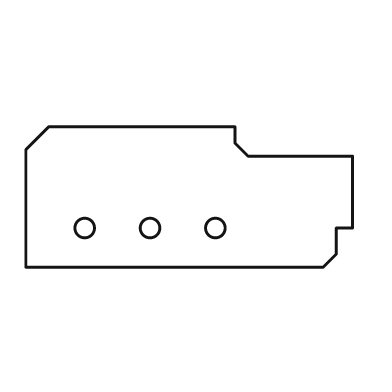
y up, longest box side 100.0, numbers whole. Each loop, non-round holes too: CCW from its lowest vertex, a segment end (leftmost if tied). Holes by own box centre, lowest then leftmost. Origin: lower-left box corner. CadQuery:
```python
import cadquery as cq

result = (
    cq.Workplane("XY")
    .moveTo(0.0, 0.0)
    .lineTo(91.0, 0.0)
    .lineTo(95.0, 4.0)
    .lineTo(95.0, 12.0)
    .lineTo(100.0, 12.0)
    .lineTo(100.0, 34.0)
    .lineTo(68.0, 34.0)
    .lineTo(64.0, 38.0)
    .lineTo(64.0, 43.0)
    .lineTo(7.0, 43.0)
    .lineTo(0.0, 36.0)
    .close()
    .moveTo(18.0, 12.0)
    .circle(3.0)
    .moveTo(38.0, 12.0)
    .circle(3.0)
    .moveTo(58.0, 12.0)
    .circle(3.0)
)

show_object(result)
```